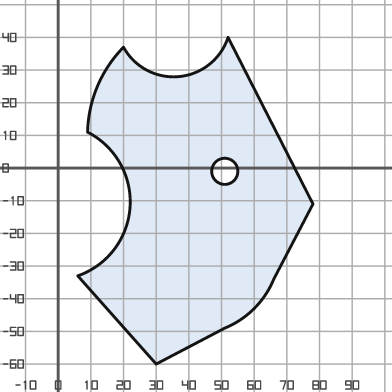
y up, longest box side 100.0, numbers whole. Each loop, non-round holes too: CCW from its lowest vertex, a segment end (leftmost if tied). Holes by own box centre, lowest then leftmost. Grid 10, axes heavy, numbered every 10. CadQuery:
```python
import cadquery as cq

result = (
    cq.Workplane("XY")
    .moveTo(30.0, -60.0)
    .lineTo(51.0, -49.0)
    .threePointArc((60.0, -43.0), (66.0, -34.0))
    .lineTo(78.0, -11.0)
    .lineTo(52.0, 40.0)
    .threePointArc((37.0, 28.0), (20.0, 37.0))
    .threePointArc((12.0, 25.0), (9.0, 11.0))
    .threePointArc((22.0, -12.0), (6.0, -33.0))
    .close()
    .moveTo(51.0, -1.0)
    .circle(4.0)
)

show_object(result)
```